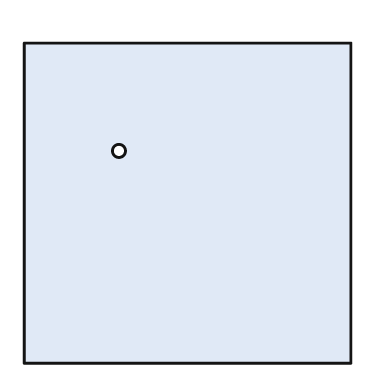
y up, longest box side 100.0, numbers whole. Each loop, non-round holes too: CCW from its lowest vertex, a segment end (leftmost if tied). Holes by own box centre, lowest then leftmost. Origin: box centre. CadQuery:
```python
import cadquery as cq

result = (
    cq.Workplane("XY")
    .moveTo(-50.0, -49.0)
    .lineTo(50.0, -49.0)
    .lineTo(50.0, 49.0)
    .lineTo(-50.0, 49.0)
    .close()
    .moveTo(-21.0, 16.0)
    .circle(2.0)
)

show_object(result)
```